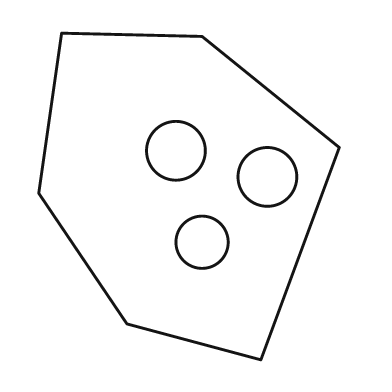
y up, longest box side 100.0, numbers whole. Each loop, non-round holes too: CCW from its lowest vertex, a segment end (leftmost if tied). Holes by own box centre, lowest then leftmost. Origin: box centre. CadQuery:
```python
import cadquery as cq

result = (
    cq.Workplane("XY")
    .moveTo(22.0, -50.0)
    .lineTo(46.0, 15.0)
    .lineTo(4.0, 49.0)
    .lineTo(-39.0, 50.0)
    .lineTo(-46.0, 1.0)
    .lineTo(-19.0, -39.0)
    .close()
    .moveTo(4.0, -14.0)
    .circle(8.0)
    .moveTo(24.0, 6.0)
    .circle(9.0)
    .moveTo(-4.0, 14.0)
    .circle(9.0)
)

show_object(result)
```